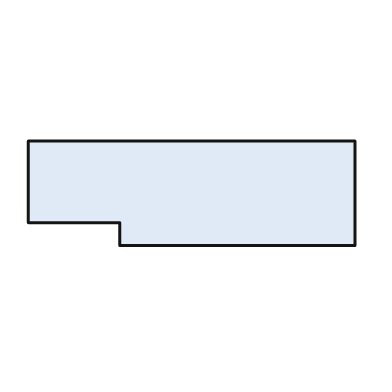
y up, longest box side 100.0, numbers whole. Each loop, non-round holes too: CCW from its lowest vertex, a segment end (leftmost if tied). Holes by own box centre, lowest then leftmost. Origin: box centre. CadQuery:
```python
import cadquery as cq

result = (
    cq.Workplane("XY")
    .moveTo(-22.0, -16.0)
    .lineTo(50.0, -16.0)
    .lineTo(50.0, 16.0)
    .lineTo(-50.0, 16.0)
    .lineTo(-50.0, -9.0)
    .lineTo(-22.0, -9.0)
    .close()
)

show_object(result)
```